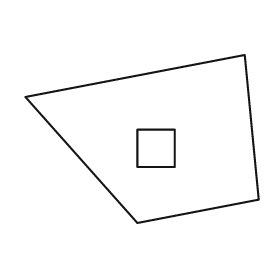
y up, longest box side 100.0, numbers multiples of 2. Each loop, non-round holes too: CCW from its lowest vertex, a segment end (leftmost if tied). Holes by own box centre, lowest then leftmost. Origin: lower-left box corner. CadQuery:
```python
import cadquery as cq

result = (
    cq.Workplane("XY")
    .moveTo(48.0, 0.0)
    .lineTo(100.0, 10.0)
    .lineTo(94.0, 72.0)
    .lineTo(0.0, 54.0)
    .close()
    .moveTo(48.0, 24.0)
    .lineTo(64.0, 24.0)
    .lineTo(64.0, 40.0)
    .lineTo(48.0, 40.0)
    .close()
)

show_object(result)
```